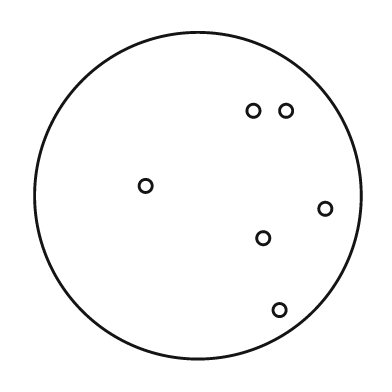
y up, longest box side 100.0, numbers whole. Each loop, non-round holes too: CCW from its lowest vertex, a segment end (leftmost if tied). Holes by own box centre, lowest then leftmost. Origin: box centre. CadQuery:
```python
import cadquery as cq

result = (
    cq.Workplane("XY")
    .moveTo(0.0, 0.0)
    .circle(50.0)
    .moveTo(25.0, -35.0)
    .circle(2.0)
    .moveTo(20.0, -13.0)
    .circle(2.0)
    .moveTo(39.0, -4.0)
    .circle(2.0)
    .moveTo(-16.0, 3.0)
    .circle(2.0)
    .moveTo(17.0, 26.0)
    .circle(2.0)
    .moveTo(27.0, 26.0)
    .circle(2.0)
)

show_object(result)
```